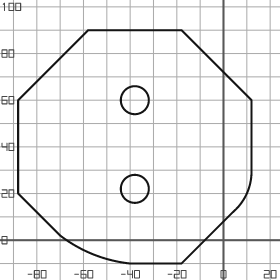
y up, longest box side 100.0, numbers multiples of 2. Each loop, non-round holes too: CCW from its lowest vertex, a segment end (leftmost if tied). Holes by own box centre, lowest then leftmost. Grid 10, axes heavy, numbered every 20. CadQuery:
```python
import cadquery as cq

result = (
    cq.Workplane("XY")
    .moveTo(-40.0, -10.0)
    .lineTo(-18.0, -10.0)
    .lineTo(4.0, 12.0)
    .threePointArc((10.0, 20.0), (12.0, 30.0))
    .lineTo(12.0, 60.0)
    .lineTo(-18.0, 90.0)
    .lineTo(-58.0, 90.0)
    .lineTo(-88.0, 60.0)
    .lineTo(-88.0, 20.0)
    .lineTo(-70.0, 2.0)
    .threePointArc((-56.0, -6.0), (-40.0, -10.0))
    .close()
    .moveTo(-38.0, 22.0)
    .circle(6.0)
    .moveTo(-38.0, 60.0)
    .circle(6.0)
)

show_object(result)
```